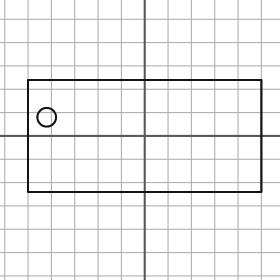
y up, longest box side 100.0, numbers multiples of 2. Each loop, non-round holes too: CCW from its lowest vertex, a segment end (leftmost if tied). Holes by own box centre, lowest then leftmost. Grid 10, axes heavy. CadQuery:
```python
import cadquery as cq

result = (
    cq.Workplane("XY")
    .moveTo(-50.0, -24.0)
    .lineTo(50.0, -24.0)
    .lineTo(50.0, 24.0)
    .lineTo(-50.0, 24.0)
    .close()
    .moveTo(-42.0, 8.0)
    .circle(4.0)
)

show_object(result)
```